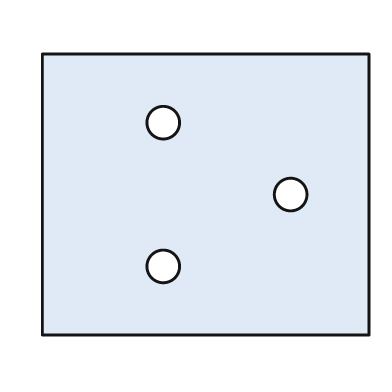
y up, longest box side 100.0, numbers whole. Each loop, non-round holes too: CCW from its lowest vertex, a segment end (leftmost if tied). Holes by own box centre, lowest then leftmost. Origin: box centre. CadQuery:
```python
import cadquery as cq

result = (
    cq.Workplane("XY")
    .moveTo(-50.0, -43.0)
    .lineTo(50.0, -43.0)
    .lineTo(50.0, 43.0)
    .lineTo(-50.0, 43.0)
    .close()
    .moveTo(-13.0, -22.0)
    .circle(5.0)
    .moveTo(26.0, 0.0)
    .circle(5.0)
    .moveTo(-13.0, 22.0)
    .circle(5.0)
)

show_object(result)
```